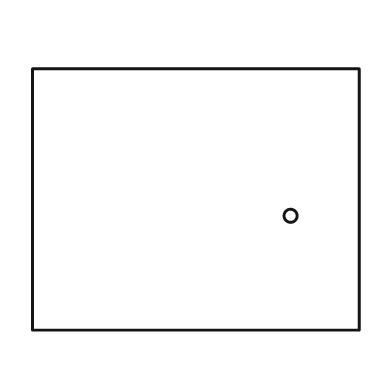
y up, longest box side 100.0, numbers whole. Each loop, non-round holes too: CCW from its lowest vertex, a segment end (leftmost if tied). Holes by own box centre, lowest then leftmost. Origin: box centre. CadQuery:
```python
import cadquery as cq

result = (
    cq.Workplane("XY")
    .moveTo(-50.0, -40.0)
    .lineTo(50.0, -40.0)
    .lineTo(50.0, 40.0)
    .lineTo(-50.0, 40.0)
    .close()
    .moveTo(29.0, -5.0)
    .circle(2.0)
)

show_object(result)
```